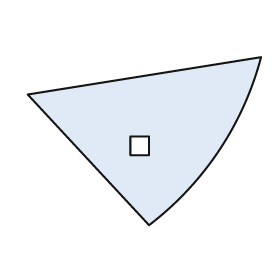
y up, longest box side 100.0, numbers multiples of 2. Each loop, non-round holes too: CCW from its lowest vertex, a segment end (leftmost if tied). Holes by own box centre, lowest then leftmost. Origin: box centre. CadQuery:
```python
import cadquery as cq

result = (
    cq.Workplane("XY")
    .moveTo(2.0, -36.0)
    .threePointArc((32.0, -4.0), (50.0, 36.0))
    .lineTo(-50.0, 20.0)
    .close()
    .moveTo(-6.0, -6.0)
    .lineTo(2.0, -6.0)
    .lineTo(2.0, 2.0)
    .lineTo(-6.0, 2.0)
    .close()
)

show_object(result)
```